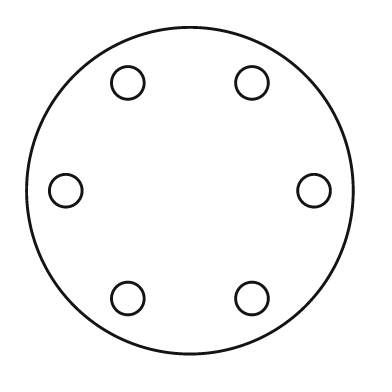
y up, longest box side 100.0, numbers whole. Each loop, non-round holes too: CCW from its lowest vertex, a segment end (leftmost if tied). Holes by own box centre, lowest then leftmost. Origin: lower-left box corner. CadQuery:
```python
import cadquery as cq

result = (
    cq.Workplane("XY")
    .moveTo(50.0, 50.0)
    .circle(50.0)
    .moveTo(31.0, 17.0)
    .circle(5.0)
    .moveTo(69.0, 17.0)
    .circle(5.0)
    .moveTo(12.0, 50.0)
    .circle(5.0)
    .moveTo(88.0, 50.0)
    .circle(5.0)
    .moveTo(31.0, 83.0)
    .circle(5.0)
    .moveTo(69.0, 83.0)
    .circle(5.0)
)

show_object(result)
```